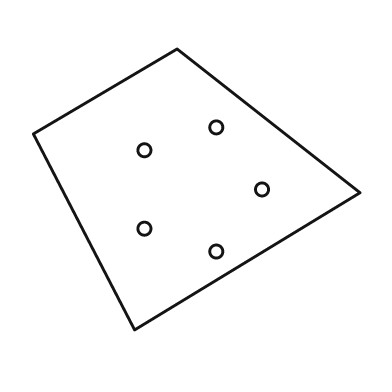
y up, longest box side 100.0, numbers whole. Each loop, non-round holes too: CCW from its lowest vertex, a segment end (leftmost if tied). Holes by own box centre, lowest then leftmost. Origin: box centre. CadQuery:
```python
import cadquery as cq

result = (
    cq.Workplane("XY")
    .moveTo(-19.0, -43.0)
    .lineTo(50.0, -1.0)
    .lineTo(-6.0, 43.0)
    .lineTo(-50.0, 17.0)
    .close()
    .moveTo(6.0, -19.0)
    .circle(2.0)
    .moveTo(-16.0, -12.0)
    .circle(2.0)
    .moveTo(20.0, 0.0)
    .circle(2.0)
    .moveTo(-16.0, 12.0)
    .circle(2.0)
    .moveTo(6.0, 19.0)
    .circle(2.0)
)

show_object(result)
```